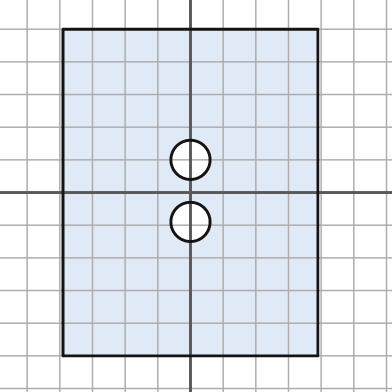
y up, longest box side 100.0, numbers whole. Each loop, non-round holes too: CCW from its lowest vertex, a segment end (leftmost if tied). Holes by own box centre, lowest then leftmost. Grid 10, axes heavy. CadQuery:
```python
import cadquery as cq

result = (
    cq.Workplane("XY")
    .moveTo(-39.0, -50.0)
    .lineTo(39.0, -50.0)
    .lineTo(39.0, 50.0)
    .lineTo(-39.0, 50.0)
    .close()
    .moveTo(0.0, -9.0)
    .circle(6.0)
    .moveTo(0.0, 10.0)
    .circle(6.0)
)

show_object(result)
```